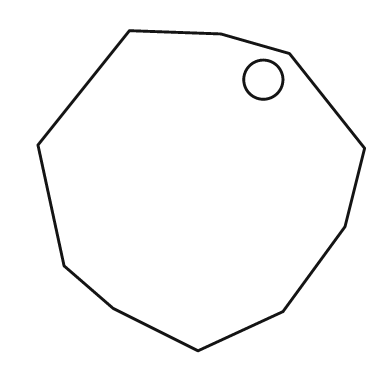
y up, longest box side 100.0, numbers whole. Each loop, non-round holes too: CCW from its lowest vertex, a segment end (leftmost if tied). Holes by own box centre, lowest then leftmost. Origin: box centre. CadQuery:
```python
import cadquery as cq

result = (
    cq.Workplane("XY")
    .moveTo(-1.0, -49.0)
    .lineTo(25.0, -37.0)
    .lineTo(44.0, -11.0)
    .lineTo(50.0, 13.0)
    .lineTo(27.0, 42.0)
    .lineTo(6.0, 48.0)
    .lineTo(-22.0, 49.0)
    .lineTo(-50.0, 14.0)
    .lineTo(-42.0, -23.0)
    .lineTo(-27.0, -36.0)
    .close()
    .moveTo(19.0, 34.0)
    .circle(6.0)
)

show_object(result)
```